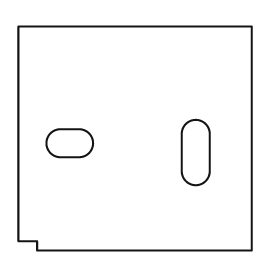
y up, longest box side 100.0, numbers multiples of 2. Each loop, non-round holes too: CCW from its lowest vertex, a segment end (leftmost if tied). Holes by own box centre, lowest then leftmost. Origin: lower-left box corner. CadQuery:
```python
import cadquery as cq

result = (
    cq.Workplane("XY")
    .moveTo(8.0, 0.0)
    .lineTo(100.0, 0.0)
    .lineTo(100.0, 96.0)
    .lineTo(0.0, 96.0)
    .lineTo(0.0, 4.0)
    .lineTo(8.0, 4.0)
    .close()
    .moveTo(70.0, 34.0)
    .threePointArc((76.0, 28.0), (82.0, 34.0))
    .lineTo(82.0, 50.0)
    .threePointArc((76.0, 56.0), (70.0, 50.0))
    .close()
    .moveTo(18.0, 40.0)
    .lineTo(26.0, 40.0)
    .threePointArc((32.0, 46.0), (26.0, 52.0))
    .lineTo(18.0, 52.0)
    .threePointArc((12.0, 46.0), (18.0, 40.0))
    .close()
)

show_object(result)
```